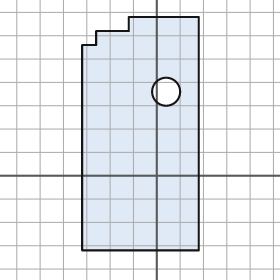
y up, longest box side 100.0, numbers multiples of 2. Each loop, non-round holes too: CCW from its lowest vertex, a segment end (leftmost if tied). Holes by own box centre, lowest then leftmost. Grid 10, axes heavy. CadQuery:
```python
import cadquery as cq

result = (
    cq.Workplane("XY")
    .moveTo(-32.0, -32.0)
    .lineTo(18.0, -32.0)
    .lineTo(18.0, 68.0)
    .lineTo(-12.0, 68.0)
    .lineTo(-12.0, 62.0)
    .lineTo(-26.0, 62.0)
    .lineTo(-26.0, 56.0)
    .lineTo(-32.0, 56.0)
    .close()
    .moveTo(4.0, 36.0)
    .circle(6.0)
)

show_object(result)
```